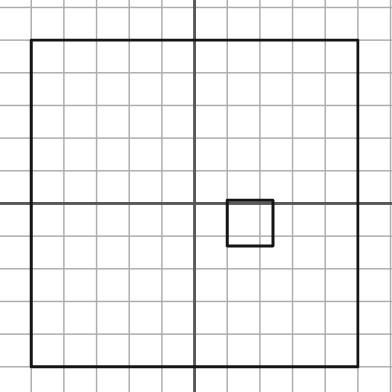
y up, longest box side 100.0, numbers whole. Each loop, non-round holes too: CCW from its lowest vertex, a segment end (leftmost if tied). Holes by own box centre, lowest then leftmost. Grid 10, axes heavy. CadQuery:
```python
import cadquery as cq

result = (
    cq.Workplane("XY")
    .moveTo(-50.0, -50.0)
    .lineTo(50.0, -50.0)
    .lineTo(50.0, 50.0)
    .lineTo(-50.0, 50.0)
    .close()
    .moveTo(10.0, -13.0)
    .lineTo(24.0, -13.0)
    .lineTo(24.0, 1.0)
    .lineTo(10.0, 1.0)
    .close()
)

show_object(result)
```